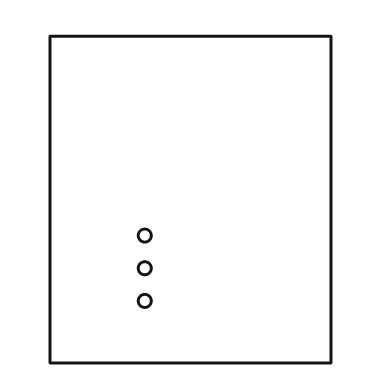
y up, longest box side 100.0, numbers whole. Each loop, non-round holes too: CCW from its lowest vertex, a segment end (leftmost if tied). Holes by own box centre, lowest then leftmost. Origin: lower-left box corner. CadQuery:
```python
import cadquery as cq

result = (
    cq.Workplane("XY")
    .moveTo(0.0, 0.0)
    .lineTo(86.0, 0.0)
    .lineTo(86.0, 100.0)
    .lineTo(0.0, 100.0)
    .close()
    .moveTo(29.0, 19.0)
    .circle(2.0)
    .moveTo(29.0, 29.0)
    .circle(2.0)
    .moveTo(29.0, 39.0)
    .circle(2.0)
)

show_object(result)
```